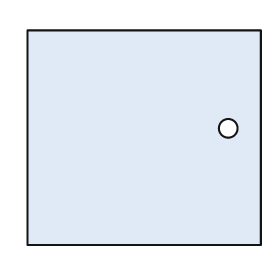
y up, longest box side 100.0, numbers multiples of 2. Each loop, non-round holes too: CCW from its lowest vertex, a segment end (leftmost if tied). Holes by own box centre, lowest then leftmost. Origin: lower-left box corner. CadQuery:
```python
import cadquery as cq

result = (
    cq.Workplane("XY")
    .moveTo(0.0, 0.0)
    .lineTo(100.0, 0.0)
    .lineTo(100.0, 92.0)
    .lineTo(0.0, 92.0)
    .close()
    .moveTo(86.0, 50.0)
    .circle(4.0)
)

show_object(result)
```